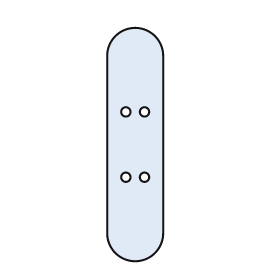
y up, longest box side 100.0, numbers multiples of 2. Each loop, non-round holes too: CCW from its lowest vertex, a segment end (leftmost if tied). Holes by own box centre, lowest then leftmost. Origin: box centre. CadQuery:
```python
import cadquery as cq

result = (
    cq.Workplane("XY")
    .moveTo(-12.0, -38.0)
    .threePointArc((0.0, -50.0), (12.0, -38.0))
    .lineTo(12.0, 38.0)
    .threePointArc((0.0, 50.0), (-12.0, 38.0))
    .close()
    .moveTo(-4.0, -14.0)
    .circle(2.0)
    .moveTo(4.0, -14.0)
    .circle(2.0)
    .moveTo(-4.0, 14.0)
    .circle(2.0)
    .moveTo(4.0, 14.0)
    .circle(2.0)
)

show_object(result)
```